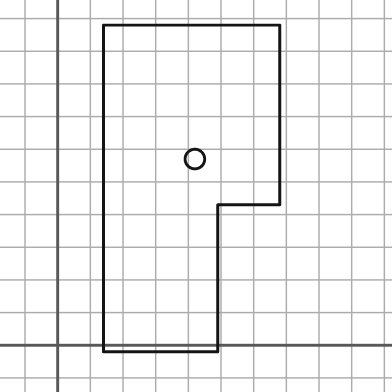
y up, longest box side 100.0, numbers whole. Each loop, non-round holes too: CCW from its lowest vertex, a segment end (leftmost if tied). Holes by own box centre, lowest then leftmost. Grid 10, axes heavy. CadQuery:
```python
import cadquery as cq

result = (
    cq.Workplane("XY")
    .moveTo(14.0, -2.0)
    .lineTo(49.0, -2.0)
    .lineTo(49.0, 43.0)
    .lineTo(68.0, 43.0)
    .lineTo(68.0, 98.0)
    .lineTo(14.0, 98.0)
    .close()
    .moveTo(42.0, 57.0)
    .circle(3.0)
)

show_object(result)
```